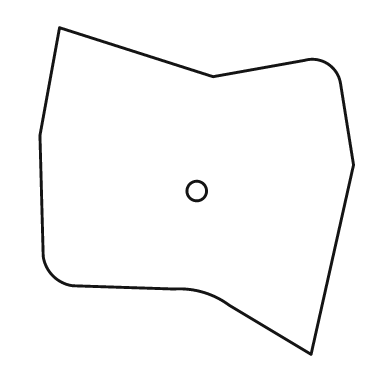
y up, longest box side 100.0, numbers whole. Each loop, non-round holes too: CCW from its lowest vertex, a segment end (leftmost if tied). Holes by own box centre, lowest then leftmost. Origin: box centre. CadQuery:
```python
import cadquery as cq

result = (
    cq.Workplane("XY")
    .moveTo(35.0, -50.0)
    .lineTo(48.0, 8.0)
    .lineTo(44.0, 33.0)
    .threePointArc((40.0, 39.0), (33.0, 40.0))
    .lineTo(5.0, 35.0)
    .lineTo(-42.0, 50.0)
    .lineTo(-48.0, 17.0)
    .lineTo(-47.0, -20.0)
    .threePointArc((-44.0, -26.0), (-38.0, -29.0))
    .lineTo(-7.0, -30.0)
    .threePointArc((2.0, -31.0), (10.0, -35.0))
    .close()
    .moveTo(0.0, 0.0)
    .circle(3.0)
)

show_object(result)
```